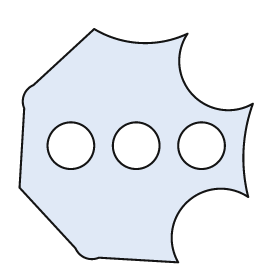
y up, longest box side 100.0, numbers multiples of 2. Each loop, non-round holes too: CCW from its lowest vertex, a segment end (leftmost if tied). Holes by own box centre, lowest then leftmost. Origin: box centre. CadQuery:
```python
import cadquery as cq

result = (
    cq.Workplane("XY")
    .moveTo(18.0, -50.0)
    .threePointArc((22.0, -24.0), (48.0, -22.0))
    .threePointArc((46.0, -2.0), (50.0, 18.0))
    .threePointArc((24.0, 22.0), (22.0, 48.0))
    .threePointArc((2.0, 44.0), (-18.0, 50.0))
    .lineTo(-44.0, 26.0)
    .threePointArc((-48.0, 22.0), (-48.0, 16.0))
    .lineTo(-50.0, -18.0)
    .lineTo(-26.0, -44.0)
    .threePointArc((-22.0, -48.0), (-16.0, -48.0))
    .close()
    .moveTo(-28.0, 0.0)
    .circle(10.0)
    .moveTo(0.0, 0.0)
    .circle(10.0)
    .moveTo(28.0, 0.0)
    .circle(10.0)
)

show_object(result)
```